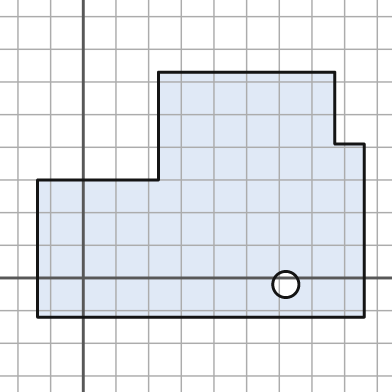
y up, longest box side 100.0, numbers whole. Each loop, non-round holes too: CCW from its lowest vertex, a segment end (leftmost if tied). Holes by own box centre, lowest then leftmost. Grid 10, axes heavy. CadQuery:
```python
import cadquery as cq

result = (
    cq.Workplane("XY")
    .moveTo(-14.0, -12.0)
    .lineTo(86.0, -12.0)
    .lineTo(86.0, 41.0)
    .lineTo(77.0, 41.0)
    .lineTo(77.0, 63.0)
    .lineTo(23.0, 63.0)
    .lineTo(23.0, 30.0)
    .lineTo(-14.0, 30.0)
    .close()
    .moveTo(62.0, -2.0)
    .circle(4.0)
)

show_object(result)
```